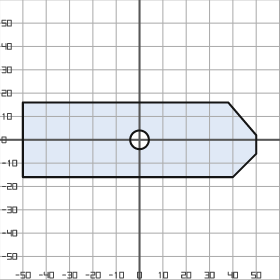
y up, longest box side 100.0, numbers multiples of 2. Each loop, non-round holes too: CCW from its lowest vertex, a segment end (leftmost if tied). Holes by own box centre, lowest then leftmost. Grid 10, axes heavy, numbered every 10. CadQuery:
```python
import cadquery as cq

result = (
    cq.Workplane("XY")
    .moveTo(-50.0, -16.0)
    .lineTo(40.0, -16.0)
    .lineTo(50.0, -6.0)
    .lineTo(50.0, 2.0)
    .lineTo(38.0, 16.0)
    .lineTo(-50.0, 16.0)
    .close()
    .moveTo(0.0, 0.0)
    .circle(4.0)
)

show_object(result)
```